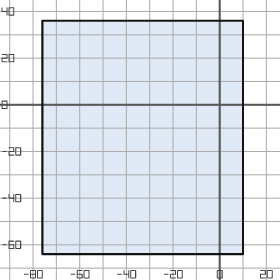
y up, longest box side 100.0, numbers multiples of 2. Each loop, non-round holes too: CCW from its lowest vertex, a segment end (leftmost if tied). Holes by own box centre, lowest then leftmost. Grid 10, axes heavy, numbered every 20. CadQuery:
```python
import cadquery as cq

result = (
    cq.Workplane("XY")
    .moveTo(-76.0, -64.0)
    .lineTo(10.0, -64.0)
    .lineTo(10.0, 36.0)
    .lineTo(-76.0, 36.0)
    .close()
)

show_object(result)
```